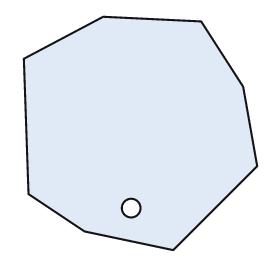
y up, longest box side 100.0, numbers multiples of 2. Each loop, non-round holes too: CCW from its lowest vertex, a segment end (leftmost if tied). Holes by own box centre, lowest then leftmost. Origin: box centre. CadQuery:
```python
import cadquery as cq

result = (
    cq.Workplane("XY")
    .moveTo(14.0, -50.0)
    .lineTo(50.0, -14.0)
    .lineTo(44.0, 20.0)
    .lineTo(26.0, 48.0)
    .lineTo(-16.0, 50.0)
    .lineTo(-50.0, 32.0)
    .lineTo(-48.0, -26.0)
    .lineTo(-24.0, -42.0)
    .close()
    .moveTo(-4.0, -32.0)
    .circle(4.0)
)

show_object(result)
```